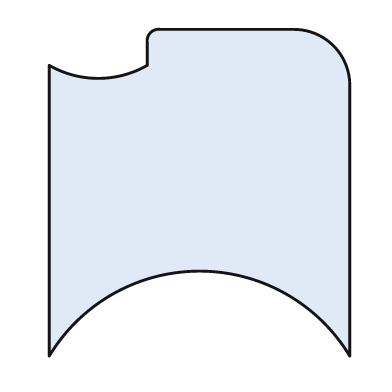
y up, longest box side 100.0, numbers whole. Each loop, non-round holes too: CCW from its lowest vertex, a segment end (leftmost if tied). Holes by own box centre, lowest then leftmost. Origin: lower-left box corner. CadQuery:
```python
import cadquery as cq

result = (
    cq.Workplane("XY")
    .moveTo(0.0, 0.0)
    .threePointArc((46.0, 26.0), (92.0, 0.0))
    .lineTo(92.0, 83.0)
    .threePointArc((87.0, 95.0), (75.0, 100.0))
    .lineTo(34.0, 100.0)
    .threePointArc((31.0, 99.0), (30.0, 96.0))
    .lineTo(30.0, 89.0)
    .threePointArc((15.0, 85.0), (0.0, 89.0))
    .close()
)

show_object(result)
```